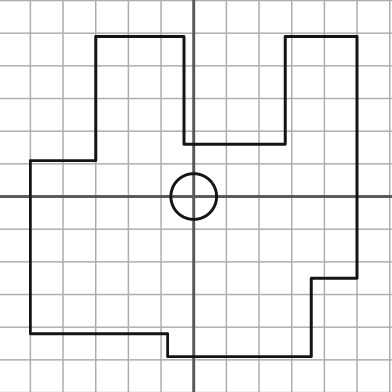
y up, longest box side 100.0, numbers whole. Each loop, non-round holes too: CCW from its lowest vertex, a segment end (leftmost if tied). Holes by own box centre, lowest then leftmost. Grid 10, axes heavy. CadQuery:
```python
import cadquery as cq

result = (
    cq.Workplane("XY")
    .moveTo(-8.0, -49.0)
    .lineTo(36.0, -49.0)
    .lineTo(36.0, -25.0)
    .lineTo(50.0, -25.0)
    .lineTo(50.0, 49.0)
    .lineTo(28.0, 49.0)
    .lineTo(28.0, 16.0)
    .lineTo(-3.0, 16.0)
    .lineTo(-3.0, 49.0)
    .lineTo(-30.0, 49.0)
    .lineTo(-30.0, 11.0)
    .lineTo(-50.0, 11.0)
    .lineTo(-50.0, -42.0)
    .lineTo(-8.0, -42.0)
    .close()
    .moveTo(0.0, 0.0)
    .circle(7.0)
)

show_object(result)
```